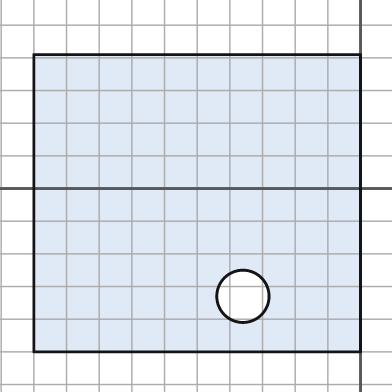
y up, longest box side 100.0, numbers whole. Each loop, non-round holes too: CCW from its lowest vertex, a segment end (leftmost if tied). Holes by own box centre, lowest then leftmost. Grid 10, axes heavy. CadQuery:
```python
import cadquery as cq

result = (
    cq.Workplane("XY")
    .moveTo(-100.0, -50.0)
    .lineTo(0.0, -50.0)
    .lineTo(0.0, 41.0)
    .lineTo(-100.0, 41.0)
    .close()
    .moveTo(-36.0, -33.0)
    .circle(8.0)
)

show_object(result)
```